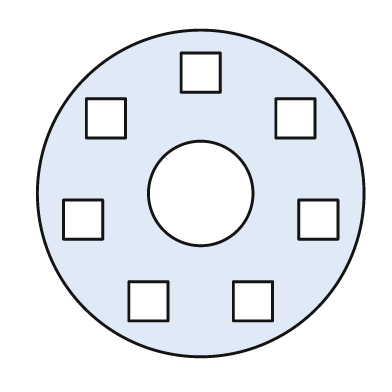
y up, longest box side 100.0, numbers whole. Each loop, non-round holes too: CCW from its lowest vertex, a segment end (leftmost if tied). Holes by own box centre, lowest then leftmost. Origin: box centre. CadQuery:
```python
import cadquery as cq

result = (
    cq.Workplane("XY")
    .moveTo(0.0, 0.0)
    .circle(50.0)
    .moveTo(-22.0, -39.0)
    .lineTo(-10.0, -39.0)
    .lineTo(-10.0, -27.0)
    .lineTo(-22.0, -27.0)
    .close()
    .moveTo(10.0, -39.0)
    .lineTo(22.0, -39.0)
    .lineTo(22.0, -27.0)
    .lineTo(10.0, -27.0)
    .close()
    .moveTo(-42.0, -14.0)
    .lineTo(-30.0, -14.0)
    .lineTo(-30.0, -2.0)
    .lineTo(-42.0, -2.0)
    .close()
    .moveTo(30.0, -14.0)
    .lineTo(42.0, -14.0)
    .lineTo(42.0, -2.0)
    .lineTo(30.0, -2.0)
    .close()
    .moveTo(0.0, 0.0)
    .circle(16.0)
    .moveTo(-35.0, 17.0)
    .lineTo(-23.0, 17.0)
    .lineTo(-23.0, 29.0)
    .lineTo(-35.0, 29.0)
    .close()
    .moveTo(23.0, 17.0)
    .lineTo(35.0, 17.0)
    .lineTo(35.0, 29.0)
    .lineTo(23.0, 29.0)
    .close()
    .moveTo(-6.0, 31.0)
    .lineTo(6.0, 31.0)
    .lineTo(6.0, 43.0)
    .lineTo(-6.0, 43.0)
    .close()
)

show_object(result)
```